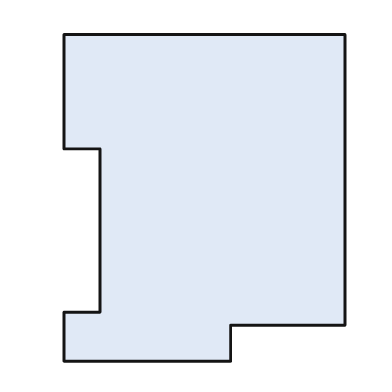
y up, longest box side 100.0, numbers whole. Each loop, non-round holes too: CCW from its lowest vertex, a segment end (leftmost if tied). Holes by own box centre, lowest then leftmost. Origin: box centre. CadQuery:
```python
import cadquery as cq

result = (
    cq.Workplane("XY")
    .moveTo(-43.0, -50.0)
    .lineTo(8.0, -50.0)
    .lineTo(8.0, -39.0)
    .lineTo(43.0, -39.0)
    .lineTo(43.0, 50.0)
    .lineTo(-43.0, 50.0)
    .lineTo(-43.0, 15.0)
    .lineTo(-32.0, 15.0)
    .lineTo(-32.0, -35.0)
    .lineTo(-43.0, -35.0)
    .close()
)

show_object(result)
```